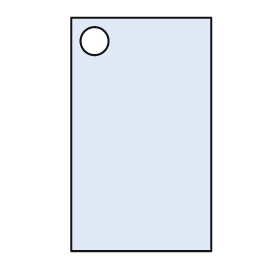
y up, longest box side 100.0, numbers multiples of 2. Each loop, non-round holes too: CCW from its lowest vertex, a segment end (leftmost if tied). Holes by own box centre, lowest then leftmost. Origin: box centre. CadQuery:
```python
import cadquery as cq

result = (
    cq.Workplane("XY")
    .moveTo(-30.0, -50.0)
    .lineTo(30.0, -50.0)
    .lineTo(30.0, 50.0)
    .lineTo(-30.0, 50.0)
    .close()
    .moveTo(-20.0, 40.0)
    .circle(6.0)
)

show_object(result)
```